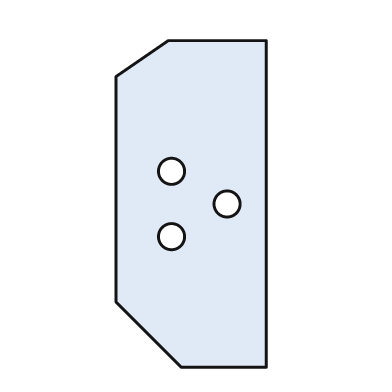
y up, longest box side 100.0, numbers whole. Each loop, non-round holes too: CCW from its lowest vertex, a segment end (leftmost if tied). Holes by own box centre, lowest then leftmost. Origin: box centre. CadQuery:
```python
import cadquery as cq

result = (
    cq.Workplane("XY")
    .moveTo(-3.0, -50.0)
    .lineTo(23.0, -50.0)
    .lineTo(23.0, 50.0)
    .lineTo(-7.0, 50.0)
    .lineTo(-23.0, 39.0)
    .lineTo(-23.0, -30.0)
    .close()
    .moveTo(-6.0, -10.0)
    .circle(4.0)
    .moveTo(11.0, 0.0)
    .circle(4.0)
    .moveTo(-6.0, 10.0)
    .circle(4.0)
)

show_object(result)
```